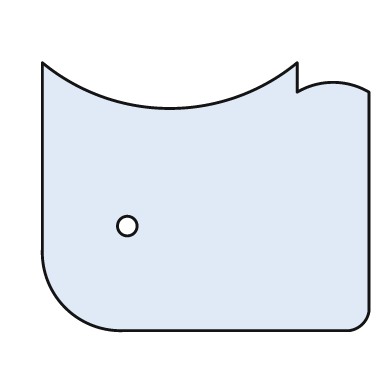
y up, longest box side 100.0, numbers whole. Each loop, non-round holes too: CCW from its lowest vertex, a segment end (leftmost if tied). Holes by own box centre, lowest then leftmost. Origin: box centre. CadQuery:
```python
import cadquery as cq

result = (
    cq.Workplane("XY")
    .moveTo(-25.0, -41.0)
    .lineTo(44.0, -41.0)
    .threePointArc((48.0, -39.0), (50.0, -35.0))
    .lineTo(50.0, 32.0)
    .threePointArc((39.0, 35.0), (28.0, 32.0))
    .lineTo(28.0, 41.0)
    .threePointArc((-11.0, 27.0), (-50.0, 41.0))
    .lineTo(-50.0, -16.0)
    .threePointArc((-43.0, -34.0), (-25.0, -41.0))
    .close()
    .moveTo(-24.0, -9.0)
    .circle(3.0)
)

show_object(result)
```